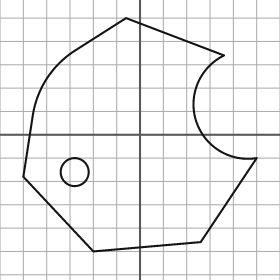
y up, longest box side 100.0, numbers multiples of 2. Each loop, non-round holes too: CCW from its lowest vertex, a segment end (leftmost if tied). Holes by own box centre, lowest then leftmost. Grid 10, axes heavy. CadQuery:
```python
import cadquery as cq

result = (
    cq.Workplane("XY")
    .moveTo(-20.0, -50.0)
    .lineTo(26.0, -46.0)
    .lineTo(50.0, -10.0)
    .threePointArc((24.0, 6.0), (36.0, 34.0))
    .lineTo(-6.0, 50.0)
    .lineTo(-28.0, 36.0)
    .threePointArc((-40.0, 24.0), (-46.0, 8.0))
    .lineTo(-50.0, -18.0)
    .close()
    .moveTo(-28.0, -16.0)
    .circle(6.0)
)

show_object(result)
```